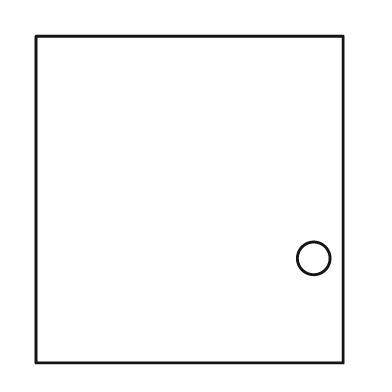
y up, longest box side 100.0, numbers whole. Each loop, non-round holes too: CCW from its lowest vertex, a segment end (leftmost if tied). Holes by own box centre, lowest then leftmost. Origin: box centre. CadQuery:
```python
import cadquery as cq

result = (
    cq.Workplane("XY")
    .moveTo(-47.0, -50.0)
    .lineTo(47.0, -50.0)
    .lineTo(47.0, 50.0)
    .lineTo(-47.0, 50.0)
    .close()
    .moveTo(38.0, -18.0)
    .circle(5.0)
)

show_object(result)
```